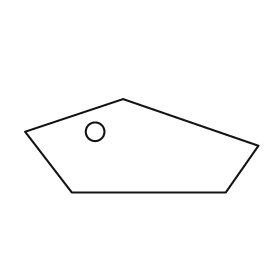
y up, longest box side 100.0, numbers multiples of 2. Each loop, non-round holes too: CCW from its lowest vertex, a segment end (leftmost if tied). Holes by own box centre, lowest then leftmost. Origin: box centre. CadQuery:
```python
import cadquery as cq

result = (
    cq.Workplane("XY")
    .moveTo(-30.0, -20.0)
    .lineTo(36.0, -20.0)
    .lineTo(50.0, 0.0)
    .lineTo(-8.0, 20.0)
    .lineTo(-50.0, 6.0)
    .close()
    .moveTo(-20.0, 6.0)
    .circle(4.0)
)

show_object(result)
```